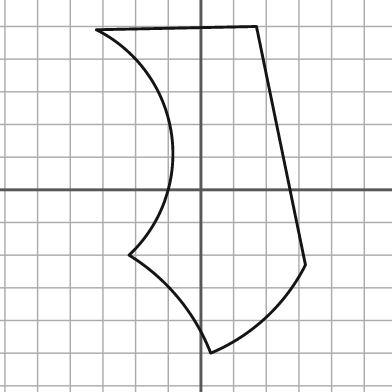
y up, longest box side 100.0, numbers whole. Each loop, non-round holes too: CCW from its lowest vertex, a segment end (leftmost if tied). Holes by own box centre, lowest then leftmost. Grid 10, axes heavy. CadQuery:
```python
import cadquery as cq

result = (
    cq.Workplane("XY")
    .moveTo(3.0, -50.0)
    .threePointArc((20.0, -39.0), (32.0, -23.0))
    .lineTo(17.0, 50.0)
    .lineTo(-32.0, 49.0)
    .threePointArc((-9.0, 17.0), (-22.0, -20.0))
    .threePointArc((-7.0, -33.0), (3.0, -50.0))
    .close()
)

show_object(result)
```